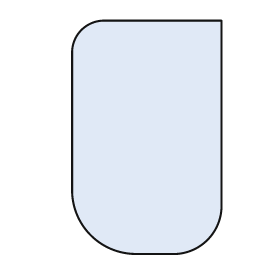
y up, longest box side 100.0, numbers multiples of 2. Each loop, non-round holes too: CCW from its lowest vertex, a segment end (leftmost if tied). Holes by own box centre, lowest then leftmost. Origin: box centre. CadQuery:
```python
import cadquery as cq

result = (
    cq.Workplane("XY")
    .moveTo(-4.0, -50.0)
    .lineTo(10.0, -50.0)
    .threePointArc((26.0, -44.0), (32.0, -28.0))
    .lineTo(32.0, 50.0)
    .lineTo(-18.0, 50.0)
    .threePointArc((-28.0, 46.0), (-32.0, 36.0))
    .lineTo(-32.0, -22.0)
    .threePointArc((-24.0, -42.0), (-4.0, -50.0))
    .close()
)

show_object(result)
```